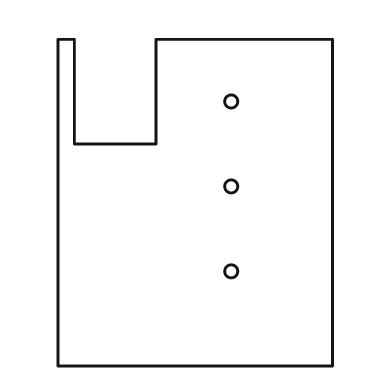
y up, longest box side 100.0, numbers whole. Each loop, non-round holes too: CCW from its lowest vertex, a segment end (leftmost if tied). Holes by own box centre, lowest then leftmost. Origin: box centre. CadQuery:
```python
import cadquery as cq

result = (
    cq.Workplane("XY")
    .moveTo(-42.0, -50.0)
    .lineTo(42.0, -50.0)
    .lineTo(42.0, 50.0)
    .lineTo(-12.0, 50.0)
    .lineTo(-12.0, 18.0)
    .lineTo(-37.0, 18.0)
    .lineTo(-37.0, 50.0)
    .lineTo(-42.0, 50.0)
    .close()
    .moveTo(11.0, -21.0)
    .circle(2.0)
    .moveTo(11.0, 5.0)
    .circle(2.0)
    .moveTo(11.0, 31.0)
    .circle(2.0)
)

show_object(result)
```